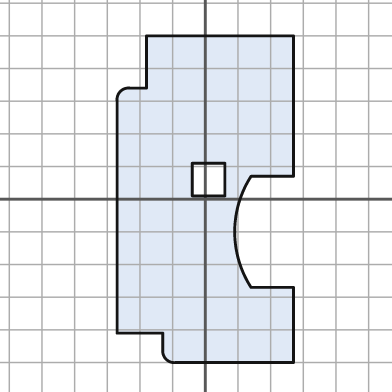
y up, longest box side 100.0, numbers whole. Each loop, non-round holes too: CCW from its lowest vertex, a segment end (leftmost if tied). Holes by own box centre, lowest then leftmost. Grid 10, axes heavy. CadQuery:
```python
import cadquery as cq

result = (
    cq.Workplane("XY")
    .moveTo(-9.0, -50.0)
    .lineTo(27.0, -50.0)
    .lineTo(27.0, -27.0)
    .lineTo(14.0, -27.0)
    .threePointArc((9.0, -10.0), (14.0, 7.0))
    .lineTo(27.0, 7.0)
    .lineTo(27.0, 50.0)
    .lineTo(-18.0, 50.0)
    .lineTo(-18.0, 34.0)
    .lineTo(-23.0, 34.0)
    .threePointArc((-26.0, 33.0), (-27.0, 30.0))
    .lineTo(-27.0, -41.0)
    .lineTo(-13.0, -41.0)
    .lineTo(-13.0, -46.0)
    .threePointArc((-12.0, -49.0), (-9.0, -50.0))
    .close()
    .moveTo(-4.0, 1.0)
    .lineTo(6.0, 1.0)
    .lineTo(6.0, 11.0)
    .lineTo(-4.0, 11.0)
    .close()
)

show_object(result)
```